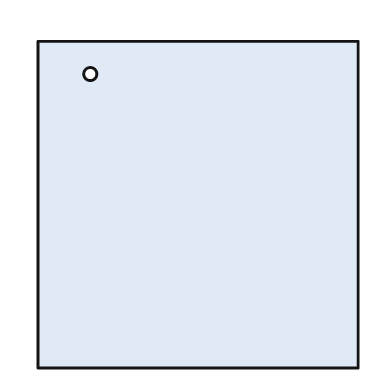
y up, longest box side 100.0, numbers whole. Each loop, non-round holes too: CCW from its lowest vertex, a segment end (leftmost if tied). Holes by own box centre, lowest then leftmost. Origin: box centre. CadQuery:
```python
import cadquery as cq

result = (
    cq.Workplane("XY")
    .moveTo(-49.0, -50.0)
    .lineTo(49.0, -50.0)
    .lineTo(49.0, 50.0)
    .lineTo(-49.0, 50.0)
    .close()
    .moveTo(-33.0, 40.0)
    .circle(2.0)
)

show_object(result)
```